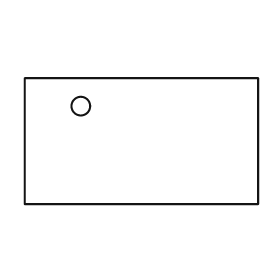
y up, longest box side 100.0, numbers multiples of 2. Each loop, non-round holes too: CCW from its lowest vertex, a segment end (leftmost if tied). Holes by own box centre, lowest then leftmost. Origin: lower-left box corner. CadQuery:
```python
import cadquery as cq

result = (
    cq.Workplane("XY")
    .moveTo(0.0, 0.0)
    .lineTo(100.0, 0.0)
    .lineTo(100.0, 54.0)
    .lineTo(0.0, 54.0)
    .close()
    .moveTo(24.0, 42.0)
    .circle(4.0)
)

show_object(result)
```